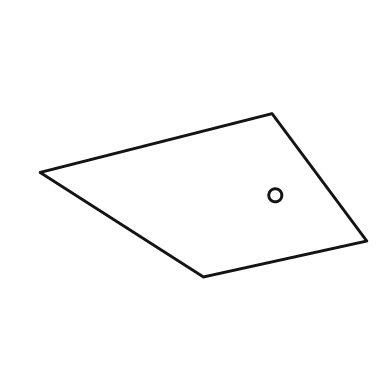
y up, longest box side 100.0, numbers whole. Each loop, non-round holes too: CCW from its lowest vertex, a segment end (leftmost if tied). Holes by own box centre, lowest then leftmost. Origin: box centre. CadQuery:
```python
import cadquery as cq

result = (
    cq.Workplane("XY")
    .moveTo(0.0, -25.0)
    .lineTo(50.0, -14.0)
    .lineTo(21.0, 25.0)
    .lineTo(-50.0, 7.0)
    .close()
    .moveTo(22.0, 0.0)
    .circle(2.0)
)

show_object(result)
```